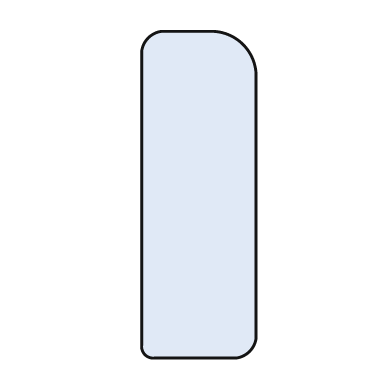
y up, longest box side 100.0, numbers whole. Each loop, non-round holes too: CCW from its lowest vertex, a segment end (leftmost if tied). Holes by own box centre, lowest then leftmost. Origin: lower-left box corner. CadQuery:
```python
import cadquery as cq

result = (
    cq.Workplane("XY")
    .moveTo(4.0, 0.0)
    .lineTo(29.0, 0.0)
    .threePointArc((33.0, 2.0), (35.0, 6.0))
    .lineTo(35.0, 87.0)
    .threePointArc((31.0, 96.0), (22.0, 100.0))
    .lineTo(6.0, 100.0)
    .threePointArc((2.0, 98.0), (0.0, 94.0))
    .lineTo(0.0, 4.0)
    .threePointArc((1.0, 1.0), (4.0, 0.0))
    .close()
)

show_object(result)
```